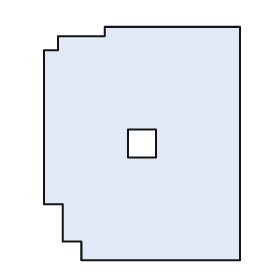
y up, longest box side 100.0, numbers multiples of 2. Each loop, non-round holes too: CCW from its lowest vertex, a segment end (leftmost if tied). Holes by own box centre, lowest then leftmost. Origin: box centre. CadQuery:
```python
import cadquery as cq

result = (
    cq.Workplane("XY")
    .moveTo(-26.0, -50.0)
    .lineTo(42.0, -50.0)
    .lineTo(42.0, 50.0)
    .lineTo(-16.0, 50.0)
    .lineTo(-16.0, 46.0)
    .lineTo(-36.0, 46.0)
    .lineTo(-36.0, 40.0)
    .lineTo(-42.0, 40.0)
    .lineTo(-42.0, -26.0)
    .lineTo(-34.0, -26.0)
    .lineTo(-34.0, -42.0)
    .lineTo(-26.0, -42.0)
    .close()
    .moveTo(-6.0, -6.0)
    .lineTo(6.0, -6.0)
    .lineTo(6.0, 6.0)
    .lineTo(-6.0, 6.0)
    .close()
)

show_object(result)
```